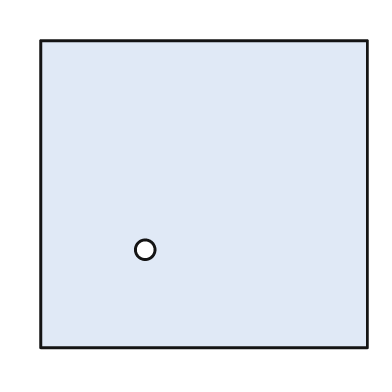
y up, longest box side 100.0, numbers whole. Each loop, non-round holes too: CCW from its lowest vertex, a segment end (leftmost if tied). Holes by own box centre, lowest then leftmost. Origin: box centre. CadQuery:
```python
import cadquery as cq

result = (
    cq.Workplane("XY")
    .moveTo(-50.0, -47.0)
    .lineTo(50.0, -47.0)
    .lineTo(50.0, 47.0)
    .lineTo(-50.0, 47.0)
    .close()
    .moveTo(-18.0, -17.0)
    .circle(3.0)
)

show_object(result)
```